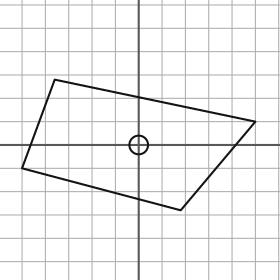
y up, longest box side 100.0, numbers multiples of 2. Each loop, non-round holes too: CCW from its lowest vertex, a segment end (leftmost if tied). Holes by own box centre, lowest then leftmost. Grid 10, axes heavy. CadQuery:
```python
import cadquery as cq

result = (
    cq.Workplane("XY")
    .moveTo(18.0, -28.0)
    .lineTo(50.0, 10.0)
    .lineTo(-36.0, 28.0)
    .lineTo(-50.0, -10.0)
    .close()
    .moveTo(0.0, 0.0)
    .circle(4.0)
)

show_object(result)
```